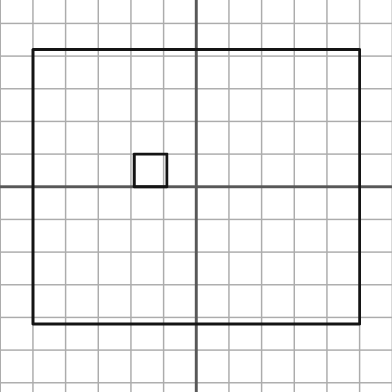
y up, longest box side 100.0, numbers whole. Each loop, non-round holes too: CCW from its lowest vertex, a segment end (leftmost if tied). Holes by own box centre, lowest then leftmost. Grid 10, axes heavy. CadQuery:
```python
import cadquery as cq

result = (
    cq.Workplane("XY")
    .moveTo(-50.0, -42.0)
    .lineTo(50.0, -42.0)
    .lineTo(50.0, 42.0)
    .lineTo(-50.0, 42.0)
    .close()
    .moveTo(-19.0, 0.0)
    .lineTo(-9.0, 0.0)
    .lineTo(-9.0, 10.0)
    .lineTo(-19.0, 10.0)
    .close()
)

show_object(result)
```